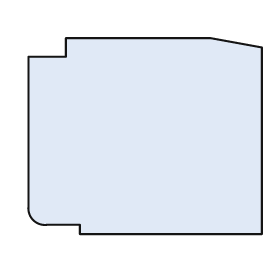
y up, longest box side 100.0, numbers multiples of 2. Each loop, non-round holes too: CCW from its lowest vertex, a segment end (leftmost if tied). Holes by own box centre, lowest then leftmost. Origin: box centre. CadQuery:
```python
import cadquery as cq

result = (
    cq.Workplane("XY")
    .moveTo(-28.0, -42.0)
    .lineTo(50.0, -42.0)
    .lineTo(50.0, 38.0)
    .lineTo(28.0, 42.0)
    .lineTo(-34.0, 42.0)
    .lineTo(-34.0, 34.0)
    .lineTo(-50.0, 34.0)
    .lineTo(-50.0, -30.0)
    .threePointArc((-48.0, -36.0), (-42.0, -38.0))
    .lineTo(-28.0, -38.0)
    .close()
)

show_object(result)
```